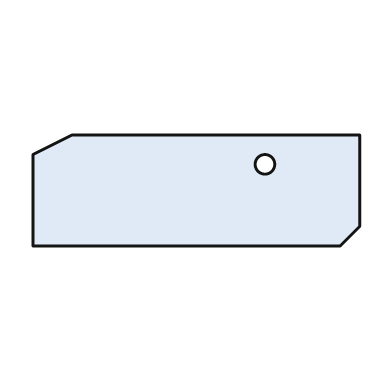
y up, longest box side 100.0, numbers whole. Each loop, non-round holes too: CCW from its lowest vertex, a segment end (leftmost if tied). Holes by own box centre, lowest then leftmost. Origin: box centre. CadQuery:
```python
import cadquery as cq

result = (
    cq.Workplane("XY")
    .moveTo(-50.0, -17.0)
    .lineTo(44.0, -17.0)
    .lineTo(50.0, -11.0)
    .lineTo(50.0, 17.0)
    .lineTo(-38.0, 17.0)
    .lineTo(-50.0, 11.0)
    .close()
    .moveTo(21.0, 8.0)
    .circle(3.0)
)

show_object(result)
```